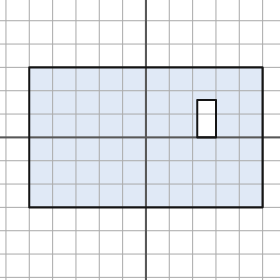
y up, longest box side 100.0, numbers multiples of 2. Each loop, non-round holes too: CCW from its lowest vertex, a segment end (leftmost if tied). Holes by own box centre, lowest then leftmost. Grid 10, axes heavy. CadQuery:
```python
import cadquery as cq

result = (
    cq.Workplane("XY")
    .moveTo(-50.0, -30.0)
    .lineTo(50.0, -30.0)
    .lineTo(50.0, 30.0)
    .lineTo(-50.0, 30.0)
    .close()
    .moveTo(22.0, 0.0)
    .lineTo(30.0, 0.0)
    .lineTo(30.0, 16.0)
    .lineTo(22.0, 16.0)
    .close()
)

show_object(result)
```